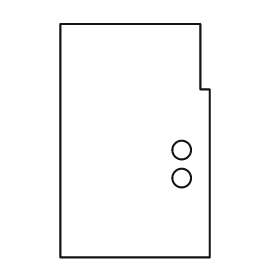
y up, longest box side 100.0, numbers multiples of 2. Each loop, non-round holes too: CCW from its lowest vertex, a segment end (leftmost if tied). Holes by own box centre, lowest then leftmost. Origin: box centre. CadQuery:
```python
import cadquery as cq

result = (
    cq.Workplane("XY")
    .moveTo(-32.0, -50.0)
    .lineTo(32.0, -50.0)
    .lineTo(32.0, 22.0)
    .lineTo(28.0, 22.0)
    .lineTo(28.0, 50.0)
    .lineTo(-32.0, 50.0)
    .close()
    .moveTo(20.0, -16.0)
    .circle(4.0)
    .moveTo(20.0, -4.0)
    .circle(4.0)
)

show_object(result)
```